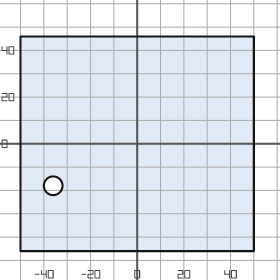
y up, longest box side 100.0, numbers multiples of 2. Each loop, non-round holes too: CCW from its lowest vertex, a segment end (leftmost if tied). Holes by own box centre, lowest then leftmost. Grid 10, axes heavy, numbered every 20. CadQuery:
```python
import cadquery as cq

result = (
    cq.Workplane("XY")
    .moveTo(-50.0, -46.0)
    .lineTo(50.0, -46.0)
    .lineTo(50.0, 46.0)
    .lineTo(-50.0, 46.0)
    .close()
    .moveTo(-36.0, -18.0)
    .circle(4.0)
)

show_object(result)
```